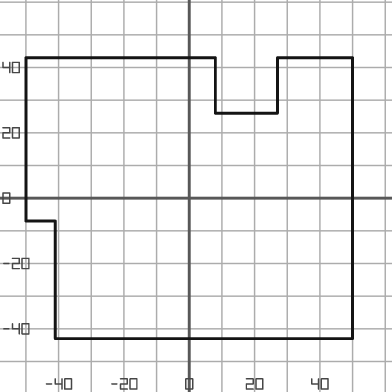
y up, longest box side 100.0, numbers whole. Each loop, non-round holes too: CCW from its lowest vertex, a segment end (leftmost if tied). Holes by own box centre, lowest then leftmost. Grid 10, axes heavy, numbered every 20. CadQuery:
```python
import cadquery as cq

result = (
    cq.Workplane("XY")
    .moveTo(-41.0, -43.0)
    .lineTo(50.0, -43.0)
    .lineTo(50.0, 43.0)
    .lineTo(27.0, 43.0)
    .lineTo(27.0, 26.0)
    .lineTo(8.0, 26.0)
    .lineTo(8.0, 43.0)
    .lineTo(-50.0, 43.0)
    .lineTo(-50.0, -7.0)
    .lineTo(-41.0, -7.0)
    .close()
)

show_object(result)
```